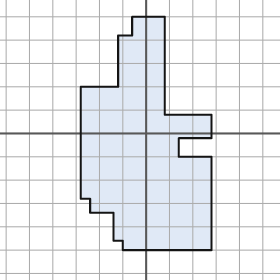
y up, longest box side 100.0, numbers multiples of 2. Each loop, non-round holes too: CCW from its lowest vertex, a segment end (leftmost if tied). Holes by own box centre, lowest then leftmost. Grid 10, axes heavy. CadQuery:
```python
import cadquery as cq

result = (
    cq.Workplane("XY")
    .moveTo(-10.0, -50.0)
    .lineTo(28.0, -50.0)
    .lineTo(28.0, -10.0)
    .lineTo(14.0, -10.0)
    .lineTo(14.0, -2.0)
    .lineTo(28.0, -2.0)
    .lineTo(28.0, 8.0)
    .lineTo(8.0, 8.0)
    .lineTo(8.0, 50.0)
    .lineTo(-6.0, 50.0)
    .lineTo(-6.0, 42.0)
    .lineTo(-12.0, 42.0)
    .lineTo(-12.0, 20.0)
    .lineTo(-28.0, 20.0)
    .lineTo(-28.0, -28.0)
    .lineTo(-24.0, -28.0)
    .lineTo(-24.0, -34.0)
    .lineTo(-14.0, -34.0)
    .lineTo(-14.0, -46.0)
    .lineTo(-10.0, -46.0)
    .close()
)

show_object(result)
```